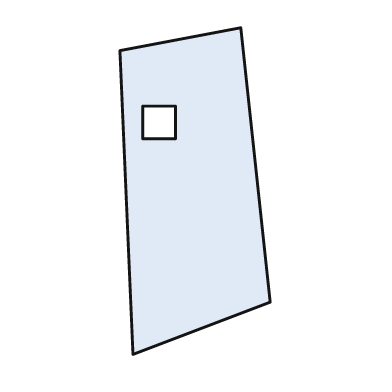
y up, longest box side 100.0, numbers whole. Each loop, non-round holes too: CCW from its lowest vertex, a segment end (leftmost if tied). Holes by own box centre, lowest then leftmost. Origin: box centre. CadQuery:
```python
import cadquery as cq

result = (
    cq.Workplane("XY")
    .moveTo(-19.0, -50.0)
    .lineTo(23.0, -34.0)
    .lineTo(14.0, 50.0)
    .lineTo(-23.0, 43.0)
    .close()
    .moveTo(-16.0, 16.0)
    .lineTo(-6.0, 16.0)
    .lineTo(-6.0, 26.0)
    .lineTo(-16.0, 26.0)
    .close()
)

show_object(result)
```